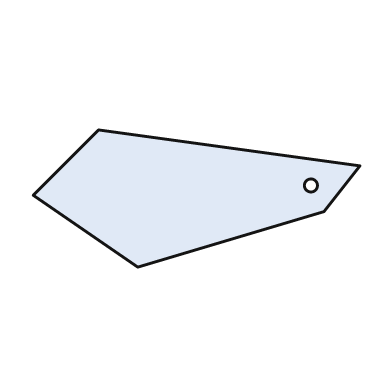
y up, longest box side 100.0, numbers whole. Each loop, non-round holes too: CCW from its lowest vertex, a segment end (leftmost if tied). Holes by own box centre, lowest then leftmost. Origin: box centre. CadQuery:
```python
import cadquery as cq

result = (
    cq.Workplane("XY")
    .moveTo(-18.0, -21.0)
    .lineTo(39.0, -4.0)
    .lineTo(50.0, 10.0)
    .lineTo(-30.0, 21.0)
    .lineTo(-50.0, 1.0)
    .close()
    .moveTo(35.0, 4.0)
    .circle(2.0)
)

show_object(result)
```